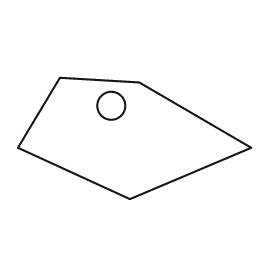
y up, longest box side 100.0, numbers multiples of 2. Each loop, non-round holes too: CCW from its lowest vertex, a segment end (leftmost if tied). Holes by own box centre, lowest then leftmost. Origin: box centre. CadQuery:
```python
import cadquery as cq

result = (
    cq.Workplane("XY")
    .moveTo(-2.0, -26.0)
    .lineTo(50.0, -4.0)
    .lineTo(2.0, 24.0)
    .lineTo(-32.0, 26.0)
    .lineTo(-50.0, -4.0)
    .close()
    .moveTo(-10.0, 14.0)
    .circle(6.0)
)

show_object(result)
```